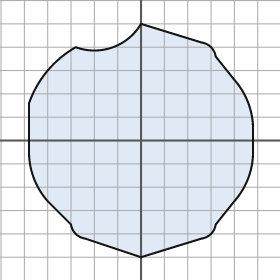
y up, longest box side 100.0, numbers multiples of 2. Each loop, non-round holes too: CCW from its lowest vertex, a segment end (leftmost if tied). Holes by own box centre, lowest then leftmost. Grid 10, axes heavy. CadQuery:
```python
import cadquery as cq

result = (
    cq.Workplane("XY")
    .moveTo(0.0, -50.0)
    .lineTo(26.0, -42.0)
    .threePointArc((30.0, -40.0), (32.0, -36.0))
    .lineTo(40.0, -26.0)
    .threePointArc((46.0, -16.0), (48.0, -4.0))
    .lineTo(48.0, 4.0)
    .threePointArc((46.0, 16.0), (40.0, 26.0))
    .lineTo(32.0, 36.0)
    .threePointArc((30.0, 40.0), (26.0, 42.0))
    .lineTo(0.0, 50.0)
    .threePointArc((-12.0, 40.0), (-28.0, 40.0))
    .threePointArc((-40.0, 30.0), (-48.0, 16.0))
    .lineTo(-48.0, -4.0)
    .threePointArc((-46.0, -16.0), (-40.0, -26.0))
    .lineTo(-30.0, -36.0)
    .threePointArc((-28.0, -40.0), (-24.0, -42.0))
    .close()
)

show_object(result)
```